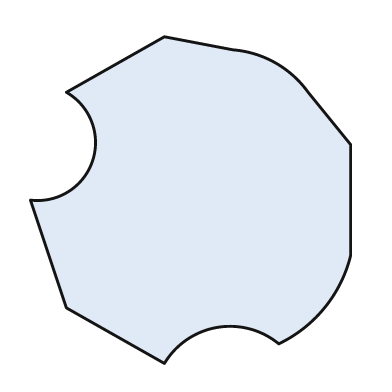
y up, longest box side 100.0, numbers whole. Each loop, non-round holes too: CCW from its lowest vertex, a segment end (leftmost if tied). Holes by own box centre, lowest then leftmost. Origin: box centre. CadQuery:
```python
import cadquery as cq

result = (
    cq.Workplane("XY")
    .moveTo(-8.0, -50.0)
    .threePointArc((8.0, -39.0), (27.0, -44.0))
    .threePointArc((41.0, -33.0), (49.0, -17.0))
    .lineTo(49.0, 17.0)
    .lineTo(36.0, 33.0)
    .threePointArc((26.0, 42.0), (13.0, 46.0))
    .lineTo(-8.0, 50.0)
    .lineTo(-38.0, 33.0)
    .threePointArc((-30.0, 12.0), (-49.0, 0.0))
    .lineTo(-38.0, -33.0)
    .close()
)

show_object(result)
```